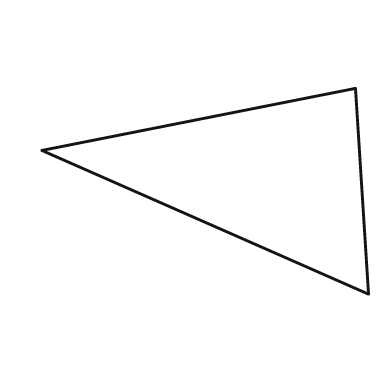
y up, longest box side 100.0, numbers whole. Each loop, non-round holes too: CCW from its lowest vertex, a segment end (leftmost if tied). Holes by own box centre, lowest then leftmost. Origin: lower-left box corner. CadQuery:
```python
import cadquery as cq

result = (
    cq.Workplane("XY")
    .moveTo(100.0, 0.0)
    .lineTo(96.0, 63.0)
    .lineTo(0.0, 44.0)
    .close()
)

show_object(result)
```